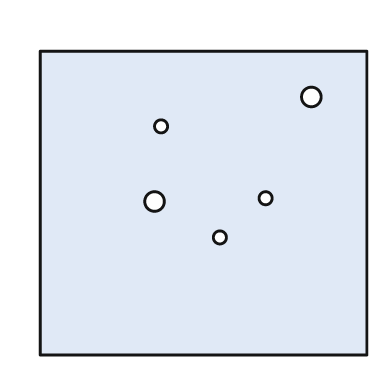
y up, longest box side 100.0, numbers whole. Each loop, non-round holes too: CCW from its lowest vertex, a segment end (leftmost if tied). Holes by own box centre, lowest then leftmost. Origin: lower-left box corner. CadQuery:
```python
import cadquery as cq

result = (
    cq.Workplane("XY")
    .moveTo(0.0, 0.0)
    .lineTo(100.0, 0.0)
    .lineTo(100.0, 93.0)
    .lineTo(0.0, 93.0)
    .close()
    .moveTo(55.0, 36.0)
    .circle(2.0)
    .moveTo(35.0, 47.0)
    .circle(3.0)
    .moveTo(69.0, 48.0)
    .circle(2.0)
    .moveTo(37.0, 70.0)
    .circle(2.0)
    .moveTo(83.0, 79.0)
    .circle(3.0)
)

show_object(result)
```